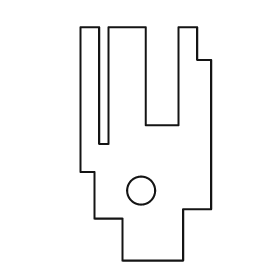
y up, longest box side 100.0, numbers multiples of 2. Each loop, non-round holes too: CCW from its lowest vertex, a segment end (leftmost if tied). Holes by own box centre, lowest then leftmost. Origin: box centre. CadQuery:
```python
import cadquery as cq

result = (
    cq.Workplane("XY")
    .moveTo(-10.0, -50.0)
    .lineTo(16.0, -50.0)
    .lineTo(16.0, -28.0)
    .lineTo(28.0, -28.0)
    .lineTo(28.0, 36.0)
    .lineTo(22.0, 36.0)
    .lineTo(22.0, 50.0)
    .lineTo(14.0, 50.0)
    .lineTo(14.0, 8.0)
    .lineTo(0.0, 8.0)
    .lineTo(0.0, 50.0)
    .lineTo(-16.0, 50.0)
    .lineTo(-16.0, 0.0)
    .lineTo(-20.0, 0.0)
    .lineTo(-20.0, 50.0)
    .lineTo(-28.0, 50.0)
    .lineTo(-28.0, -12.0)
    .lineTo(-22.0, -12.0)
    .lineTo(-22.0, -32.0)
    .lineTo(-10.0, -32.0)
    .close()
    .moveTo(-2.0, -20.0)
    .circle(6.0)
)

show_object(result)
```